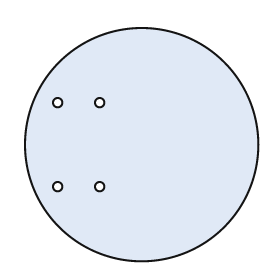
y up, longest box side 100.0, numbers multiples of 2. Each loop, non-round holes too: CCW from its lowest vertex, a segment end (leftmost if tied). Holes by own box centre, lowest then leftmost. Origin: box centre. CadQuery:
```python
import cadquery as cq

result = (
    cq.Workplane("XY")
    .moveTo(0.0, 0.0)
    .circle(50.0)
    .moveTo(-36.0, -18.0)
    .circle(2.0)
    .moveTo(-18.0, -18.0)
    .circle(2.0)
    .moveTo(-36.0, 18.0)
    .circle(2.0)
    .moveTo(-18.0, 18.0)
    .circle(2.0)
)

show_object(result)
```